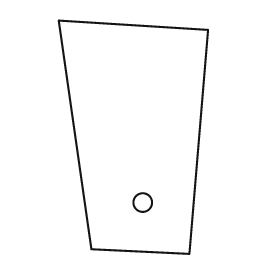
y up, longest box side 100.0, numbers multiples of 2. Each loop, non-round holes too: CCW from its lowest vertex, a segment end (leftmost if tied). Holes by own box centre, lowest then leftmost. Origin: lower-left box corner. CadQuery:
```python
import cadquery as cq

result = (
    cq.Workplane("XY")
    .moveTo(56.0, 0.0)
    .lineTo(64.0, 96.0)
    .lineTo(0.0, 100.0)
    .lineTo(14.0, 2.0)
    .close()
    .moveTo(36.0, 22.0)
    .circle(4.0)
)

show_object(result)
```